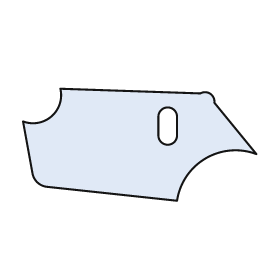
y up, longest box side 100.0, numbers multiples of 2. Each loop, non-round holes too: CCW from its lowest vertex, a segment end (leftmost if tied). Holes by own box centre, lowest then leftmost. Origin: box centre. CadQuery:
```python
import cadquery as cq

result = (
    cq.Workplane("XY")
    .moveTo(16.0, -24.0)
    .threePointArc((28.0, -6.0), (50.0, -4.0))
    .lineTo(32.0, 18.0)
    .threePointArc((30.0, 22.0), (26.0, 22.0))
    .lineTo(-34.0, 24.0)
    .threePointArc((-38.0, 12.0), (-50.0, 10.0))
    .lineTo(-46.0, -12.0)
    .threePointArc((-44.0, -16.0), (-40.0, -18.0))
    .close()
    .moveTo(8.0, 4.0)
    .threePointArc((12.0, 0.0), (16.0, 4.0))
    .lineTo(16.0, 12.0)
    .threePointArc((12.0, 16.0), (8.0, 12.0))
    .close()
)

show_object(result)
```